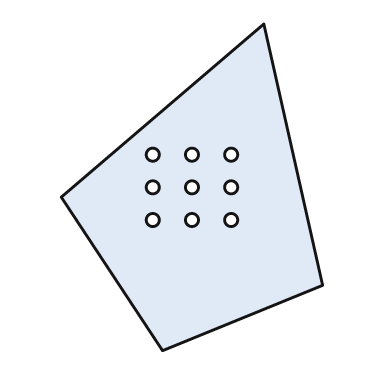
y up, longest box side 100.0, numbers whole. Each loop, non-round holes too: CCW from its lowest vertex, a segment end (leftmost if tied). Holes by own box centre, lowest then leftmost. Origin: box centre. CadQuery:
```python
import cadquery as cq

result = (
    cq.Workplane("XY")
    .moveTo(-9.0, -50.0)
    .lineTo(40.0, -30.0)
    .lineTo(22.0, 50.0)
    .lineTo(-40.0, -3.0)
    .close()
    .moveTo(-12.0, -10.0)
    .circle(2.0)
    .moveTo(0.0, -10.0)
    .circle(2.0)
    .moveTo(12.0, -10.0)
    .circle(2.0)
    .moveTo(-12.0, 0.0)
    .circle(2.0)
    .moveTo(0.0, 0.0)
    .circle(2.0)
    .moveTo(12.0, 0.0)
    .circle(2.0)
    .moveTo(-12.0, 10.0)
    .circle(2.0)
    .moveTo(0.0, 10.0)
    .circle(2.0)
    .moveTo(12.0, 10.0)
    .circle(2.0)
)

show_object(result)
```